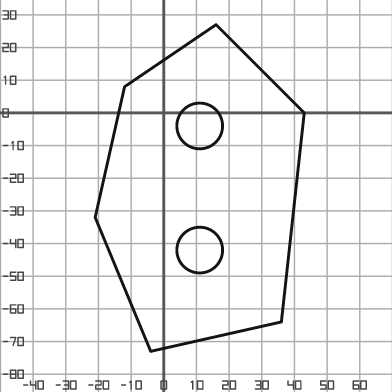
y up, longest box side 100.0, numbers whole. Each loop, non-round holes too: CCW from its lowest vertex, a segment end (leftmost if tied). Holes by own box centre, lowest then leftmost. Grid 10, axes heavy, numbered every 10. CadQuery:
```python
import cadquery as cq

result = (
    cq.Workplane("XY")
    .moveTo(-4.0, -73.0)
    .lineTo(36.0, -64.0)
    .lineTo(43.0, 0.0)
    .lineTo(16.0, 27.0)
    .lineTo(-12.0, 8.0)
    .lineTo(-21.0, -32.0)
    .close()
    .moveTo(11.0, -42.0)
    .circle(7.0)
    .moveTo(11.0, -4.0)
    .circle(7.0)
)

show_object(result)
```